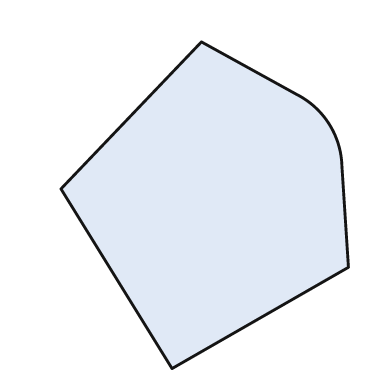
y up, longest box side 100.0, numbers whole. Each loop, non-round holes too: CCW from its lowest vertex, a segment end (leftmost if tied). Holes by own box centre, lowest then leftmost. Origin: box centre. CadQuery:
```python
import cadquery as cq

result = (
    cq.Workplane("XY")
    .moveTo(-10.0, -50.0)
    .lineTo(44.0, -19.0)
    .lineTo(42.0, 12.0)
    .threePointArc((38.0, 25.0), (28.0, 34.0))
    .lineTo(-1.0, 50.0)
    .lineTo(-44.0, 5.0)
    .close()
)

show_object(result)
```